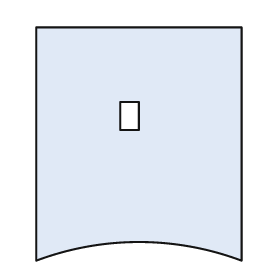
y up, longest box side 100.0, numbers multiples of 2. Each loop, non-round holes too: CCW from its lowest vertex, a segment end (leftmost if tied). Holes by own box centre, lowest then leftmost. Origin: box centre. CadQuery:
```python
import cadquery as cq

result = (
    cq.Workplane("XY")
    .moveTo(-44.0, -50.0)
    .threePointArc((0.0, -42.0), (44.0, -50.0))
    .lineTo(44.0, 50.0)
    .lineTo(-44.0, 50.0)
    .close()
    .moveTo(-8.0, 6.0)
    .lineTo(0.0, 6.0)
    .lineTo(0.0, 18.0)
    .lineTo(-8.0, 18.0)
    .close()
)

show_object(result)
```